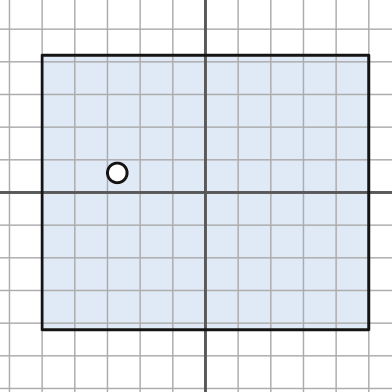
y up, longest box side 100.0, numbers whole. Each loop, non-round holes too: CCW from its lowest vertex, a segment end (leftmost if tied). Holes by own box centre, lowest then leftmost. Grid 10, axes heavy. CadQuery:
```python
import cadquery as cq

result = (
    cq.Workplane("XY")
    .moveTo(-50.0, -42.0)
    .lineTo(50.0, -42.0)
    .lineTo(50.0, 42.0)
    .lineTo(-50.0, 42.0)
    .close()
    .moveTo(-27.0, 6.0)
    .circle(3.0)
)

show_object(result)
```